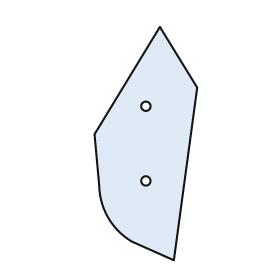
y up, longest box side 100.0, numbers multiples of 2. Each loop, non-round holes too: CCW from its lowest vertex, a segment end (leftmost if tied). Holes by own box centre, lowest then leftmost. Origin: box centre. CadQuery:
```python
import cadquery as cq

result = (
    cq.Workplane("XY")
    .moveTo(12.0, -50.0)
    .lineTo(22.0, 24.0)
    .lineTo(6.0, 50.0)
    .lineTo(-22.0, 4.0)
    .lineTo(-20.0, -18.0)
    .threePointArc((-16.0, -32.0), (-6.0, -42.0))
    .close()
    .moveTo(0.0, -16.0)
    .circle(2.0)
    .moveTo(0.0, 16.0)
    .circle(2.0)
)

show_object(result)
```